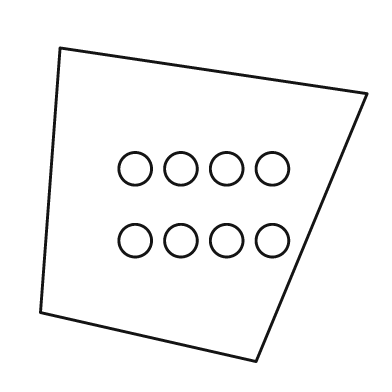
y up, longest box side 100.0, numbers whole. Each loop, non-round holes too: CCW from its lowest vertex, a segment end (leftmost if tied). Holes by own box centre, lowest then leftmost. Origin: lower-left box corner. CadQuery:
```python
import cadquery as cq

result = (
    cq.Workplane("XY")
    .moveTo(66.0, 0.0)
    .lineTo(100.0, 82.0)
    .lineTo(6.0, 96.0)
    .lineTo(0.0, 15.0)
    .close()
    .moveTo(29.0, 37.0)
    .circle(5.0)
    .moveTo(43.0, 37.0)
    .circle(5.0)
    .moveTo(57.0, 37.0)
    .circle(5.0)
    .moveTo(71.0, 37.0)
    .circle(5.0)
    .moveTo(29.0, 59.0)
    .circle(5.0)
    .moveTo(43.0, 59.0)
    .circle(5.0)
    .moveTo(57.0, 59.0)
    .circle(5.0)
    .moveTo(71.0, 59.0)
    .circle(5.0)
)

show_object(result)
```